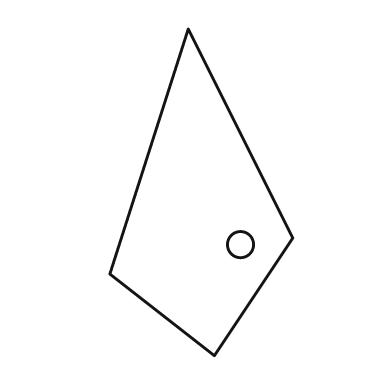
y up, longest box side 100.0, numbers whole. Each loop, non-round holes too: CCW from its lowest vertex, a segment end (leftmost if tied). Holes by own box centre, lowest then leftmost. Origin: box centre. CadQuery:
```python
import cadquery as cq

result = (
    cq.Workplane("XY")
    .moveTo(4.0, -50.0)
    .lineTo(28.0, -14.0)
    .lineTo(-4.0, 50.0)
    .lineTo(-28.0, -25.0)
    .close()
    .moveTo(12.0, -16.0)
    .circle(4.0)
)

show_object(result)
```